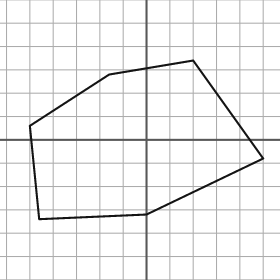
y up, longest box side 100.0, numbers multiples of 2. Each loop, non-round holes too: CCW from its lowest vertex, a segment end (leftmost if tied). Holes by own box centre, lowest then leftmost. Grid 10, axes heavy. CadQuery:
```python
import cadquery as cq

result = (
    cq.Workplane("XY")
    .moveTo(-46.0, -34.0)
    .lineTo(0.0, -32.0)
    .lineTo(50.0, -8.0)
    .lineTo(20.0, 34.0)
    .lineTo(-16.0, 28.0)
    .lineTo(-50.0, 6.0)
    .close()
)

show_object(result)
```